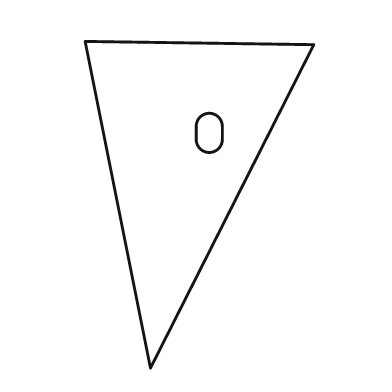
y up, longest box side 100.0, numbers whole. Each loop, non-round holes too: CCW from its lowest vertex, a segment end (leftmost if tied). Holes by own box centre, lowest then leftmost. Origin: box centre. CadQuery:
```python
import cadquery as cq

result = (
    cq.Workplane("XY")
    .moveTo(-15.0, -50.0)
    .lineTo(35.0, 49.0)
    .lineTo(-35.0, 50.0)
    .close()
    .moveTo(-1.0, 20.0)
    .threePointArc((3.0, 16.0), (7.0, 20.0))
    .lineTo(7.0, 24.0)
    .threePointArc((3.0, 28.0), (-1.0, 24.0))
    .close()
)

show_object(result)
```